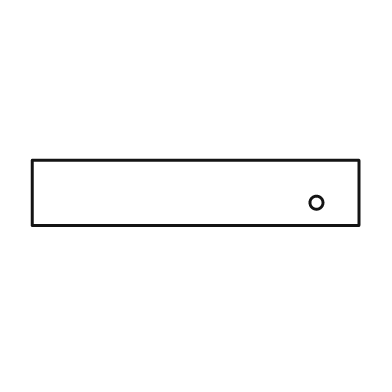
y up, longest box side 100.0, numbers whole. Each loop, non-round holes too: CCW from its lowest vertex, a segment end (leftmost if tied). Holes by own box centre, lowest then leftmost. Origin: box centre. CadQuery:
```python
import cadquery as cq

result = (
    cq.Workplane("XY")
    .moveTo(-50.0, -10.0)
    .lineTo(50.0, -10.0)
    .lineTo(50.0, 10.0)
    .lineTo(-50.0, 10.0)
    .close()
    .moveTo(37.0, -3.0)
    .circle(2.0)
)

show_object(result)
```